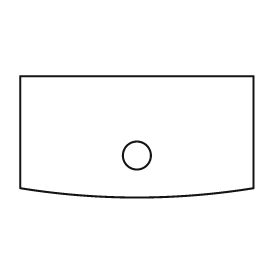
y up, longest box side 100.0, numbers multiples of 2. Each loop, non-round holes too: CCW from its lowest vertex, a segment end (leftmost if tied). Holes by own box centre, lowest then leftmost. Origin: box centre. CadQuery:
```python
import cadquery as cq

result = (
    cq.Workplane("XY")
    .moveTo(-50.0, -22.0)
    .threePointArc((0.0, -26.0), (50.0, -22.0))
    .lineTo(50.0, 26.0)
    .lineTo(-50.0, 26.0)
    .close()
    .moveTo(0.0, -8.0)
    .circle(6.0)
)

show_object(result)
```